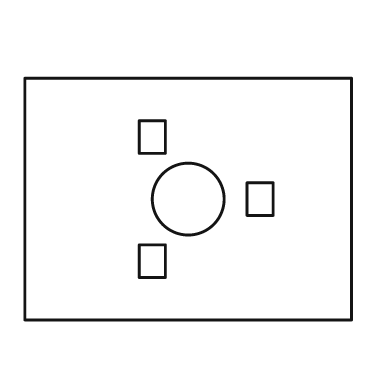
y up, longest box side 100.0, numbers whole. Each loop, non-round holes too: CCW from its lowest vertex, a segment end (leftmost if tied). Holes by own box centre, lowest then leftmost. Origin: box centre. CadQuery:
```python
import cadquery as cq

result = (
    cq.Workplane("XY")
    .moveTo(-50.0, -37.0)
    .lineTo(50.0, -37.0)
    .lineTo(50.0, 37.0)
    .lineTo(-50.0, 37.0)
    .close()
    .moveTo(-15.0, -24.0)
    .lineTo(-7.0, -24.0)
    .lineTo(-7.0, -14.0)
    .lineTo(-15.0, -14.0)
    .close()
    .moveTo(0.0, 0.0)
    .circle(11.0)
    .moveTo(18.0, -5.0)
    .lineTo(26.0, -5.0)
    .lineTo(26.0, 5.0)
    .lineTo(18.0, 5.0)
    .close()
    .moveTo(-15.0, 14.0)
    .lineTo(-7.0, 14.0)
    .lineTo(-7.0, 24.0)
    .lineTo(-15.0, 24.0)
    .close()
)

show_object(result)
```